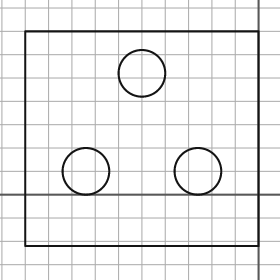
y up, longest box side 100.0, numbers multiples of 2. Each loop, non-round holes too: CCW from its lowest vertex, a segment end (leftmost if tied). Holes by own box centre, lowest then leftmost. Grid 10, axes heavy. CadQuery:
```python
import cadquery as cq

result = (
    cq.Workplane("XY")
    .moveTo(-100.0, -22.0)
    .lineTo(0.0, -22.0)
    .lineTo(0.0, 70.0)
    .lineTo(-100.0, 70.0)
    .close()
    .moveTo(-74.0, 10.0)
    .circle(10.0)
    .moveTo(-26.0, 10.0)
    .circle(10.0)
    .moveTo(-50.0, 52.0)
    .circle(10.0)
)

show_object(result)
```